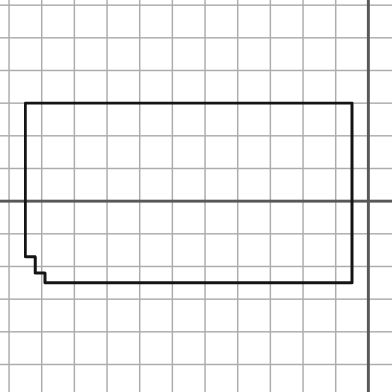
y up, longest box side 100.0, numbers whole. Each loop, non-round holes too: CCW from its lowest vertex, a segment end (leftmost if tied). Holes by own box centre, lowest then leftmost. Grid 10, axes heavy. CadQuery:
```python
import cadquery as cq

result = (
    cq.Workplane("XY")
    .moveTo(-99.0, -25.0)
    .lineTo(-5.0, -25.0)
    .lineTo(-5.0, 30.0)
    .lineTo(-105.0, 30.0)
    .lineTo(-105.0, -17.0)
    .lineTo(-102.0, -17.0)
    .lineTo(-102.0, -22.0)
    .lineTo(-99.0, -22.0)
    .close()
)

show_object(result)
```